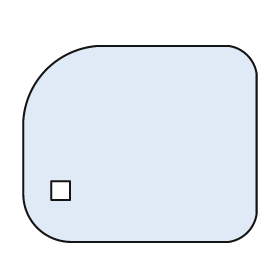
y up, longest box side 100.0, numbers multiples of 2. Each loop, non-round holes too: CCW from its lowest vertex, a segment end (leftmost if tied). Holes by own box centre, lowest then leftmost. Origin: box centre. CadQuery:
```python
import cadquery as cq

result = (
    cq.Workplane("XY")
    .moveTo(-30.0, -42.0)
    .lineTo(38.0, -42.0)
    .threePointArc((46.0, -38.0), (50.0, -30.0))
    .lineTo(50.0, 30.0)
    .threePointArc((46.0, 38.0), (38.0, 42.0))
    .lineTo(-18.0, 42.0)
    .threePointArc((-40.0, 32.0), (-50.0, 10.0))
    .lineTo(-50.0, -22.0)
    .threePointArc((-44.0, -36.0), (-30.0, -42.0))
    .close()
    .moveTo(-38.0, -24.0)
    .lineTo(-30.0, -24.0)
    .lineTo(-30.0, -16.0)
    .lineTo(-38.0, -16.0)
    .close()
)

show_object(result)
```